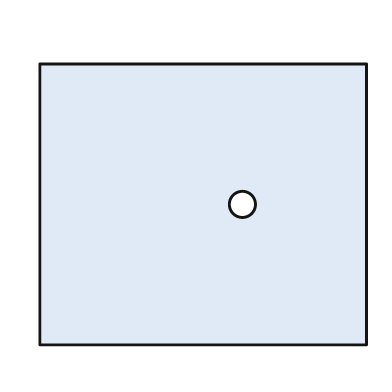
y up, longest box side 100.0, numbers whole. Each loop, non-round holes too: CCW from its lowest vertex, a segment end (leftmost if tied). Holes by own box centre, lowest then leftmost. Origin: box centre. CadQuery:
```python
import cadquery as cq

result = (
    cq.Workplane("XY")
    .moveTo(-50.0, -43.0)
    .lineTo(50.0, -43.0)
    .lineTo(50.0, 43.0)
    .lineTo(-50.0, 43.0)
    .close()
    .moveTo(12.0, 0.0)
    .circle(4.0)
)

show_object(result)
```